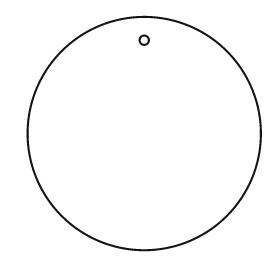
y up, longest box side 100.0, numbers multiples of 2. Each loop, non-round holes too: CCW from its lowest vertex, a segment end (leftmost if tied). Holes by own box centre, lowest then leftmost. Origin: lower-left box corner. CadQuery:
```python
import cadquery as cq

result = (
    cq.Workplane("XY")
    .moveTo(50.0, 50.0)
    .circle(50.0)
    .moveTo(50.0, 90.0)
    .circle(2.0)
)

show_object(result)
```